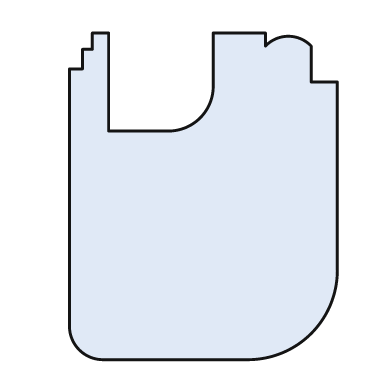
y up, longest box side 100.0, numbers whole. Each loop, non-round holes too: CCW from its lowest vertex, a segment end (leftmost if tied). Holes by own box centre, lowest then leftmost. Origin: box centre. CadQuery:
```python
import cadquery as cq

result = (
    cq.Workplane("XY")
    .moveTo(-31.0, -50.0)
    .lineTo(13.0, -50.0)
    .threePointArc((33.0, -42.0), (41.0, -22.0))
    .lineTo(41.0, 35.0)
    .lineTo(33.0, 35.0)
    .lineTo(33.0, 46.0)
    .threePointArc((26.0, 49.0), (19.0, 46.0))
    .lineTo(19.0, 50.0)
    .lineTo(3.0, 50.0)
    .lineTo(3.0, 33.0)
    .threePointArc((-1.0, 24.0), (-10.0, 20.0))
    .lineTo(-29.0, 20.0)
    .lineTo(-29.0, 50.0)
    .lineTo(-34.0, 50.0)
    .lineTo(-34.0, 45.0)
    .lineTo(-37.0, 45.0)
    .lineTo(-37.0, 39.0)
    .lineTo(-41.0, 39.0)
    .lineTo(-41.0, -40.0)
    .threePointArc((-38.0, -47.0), (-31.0, -50.0))
    .close()
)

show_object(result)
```